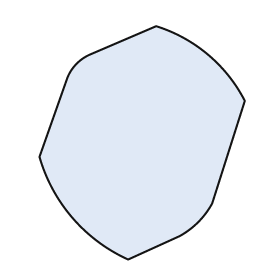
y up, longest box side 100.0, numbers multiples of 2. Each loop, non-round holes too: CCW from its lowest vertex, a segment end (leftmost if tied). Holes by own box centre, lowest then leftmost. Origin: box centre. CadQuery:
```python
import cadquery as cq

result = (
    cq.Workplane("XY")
    .moveTo(-6.0, -50.0)
    .lineTo(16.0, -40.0)
    .threePointArc((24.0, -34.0), (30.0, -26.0))
    .lineTo(44.0, 18.0)
    .threePointArc((28.0, 38.0), (6.0, 50.0))
    .lineTo(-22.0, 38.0)
    .threePointArc((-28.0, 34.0), (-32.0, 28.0))
    .lineTo(-44.0, -6.0)
    .threePointArc((-30.0, -32.0), (-6.0, -50.0))
    .close()
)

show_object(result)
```